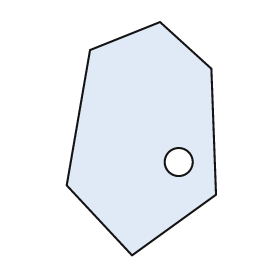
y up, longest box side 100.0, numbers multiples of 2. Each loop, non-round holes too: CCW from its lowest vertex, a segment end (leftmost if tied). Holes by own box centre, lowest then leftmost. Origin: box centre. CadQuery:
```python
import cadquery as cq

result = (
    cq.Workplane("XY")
    .moveTo(-4.0, -50.0)
    .lineTo(32.0, -24.0)
    .lineTo(30.0, 30.0)
    .lineTo(8.0, 50.0)
    .lineTo(-22.0, 38.0)
    .lineTo(-32.0, -20.0)
    .close()
    .moveTo(16.0, -10.0)
    .circle(6.0)
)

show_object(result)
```